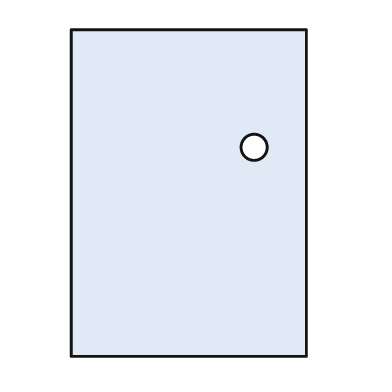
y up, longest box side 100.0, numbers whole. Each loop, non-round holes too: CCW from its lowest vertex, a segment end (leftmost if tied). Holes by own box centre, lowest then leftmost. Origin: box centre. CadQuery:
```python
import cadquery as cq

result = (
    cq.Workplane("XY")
    .moveTo(-36.0, -50.0)
    .lineTo(36.0, -50.0)
    .lineTo(36.0, 50.0)
    .lineTo(-36.0, 50.0)
    .close()
    .moveTo(20.0, 14.0)
    .circle(4.0)
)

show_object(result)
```